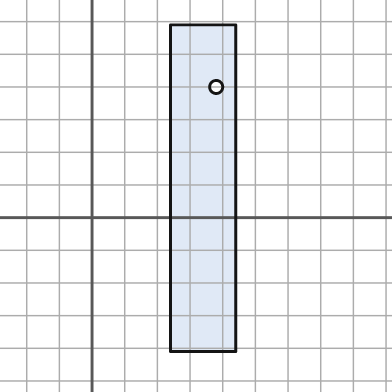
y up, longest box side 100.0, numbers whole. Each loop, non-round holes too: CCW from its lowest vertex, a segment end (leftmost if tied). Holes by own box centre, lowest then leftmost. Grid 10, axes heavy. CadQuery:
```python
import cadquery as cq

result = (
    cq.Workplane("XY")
    .moveTo(24.0, -41.0)
    .lineTo(44.0, -41.0)
    .lineTo(44.0, 59.0)
    .lineTo(24.0, 59.0)
    .close()
    .moveTo(38.0, 40.0)
    .circle(2.0)
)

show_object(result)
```